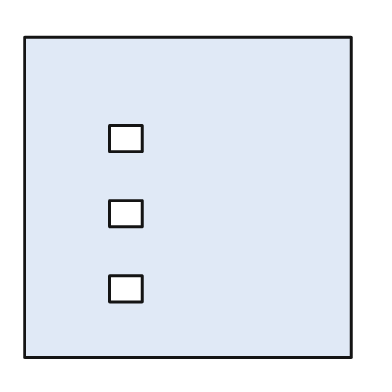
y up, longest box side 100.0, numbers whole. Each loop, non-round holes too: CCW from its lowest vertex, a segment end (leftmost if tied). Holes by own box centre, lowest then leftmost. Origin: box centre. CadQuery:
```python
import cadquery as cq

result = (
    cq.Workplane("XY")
    .moveTo(-50.0, -49.0)
    .lineTo(50.0, -49.0)
    .lineTo(50.0, 49.0)
    .lineTo(-50.0, 49.0)
    .close()
    .moveTo(-24.0, -32.0)
    .lineTo(-14.0, -32.0)
    .lineTo(-14.0, -24.0)
    .lineTo(-24.0, -24.0)
    .close()
    .moveTo(-24.0, -9.0)
    .lineTo(-14.0, -9.0)
    .lineTo(-14.0, -1.0)
    .lineTo(-24.0, -1.0)
    .close()
    .moveTo(-24.0, 14.0)
    .lineTo(-14.0, 14.0)
    .lineTo(-14.0, 22.0)
    .lineTo(-24.0, 22.0)
    .close()
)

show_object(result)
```